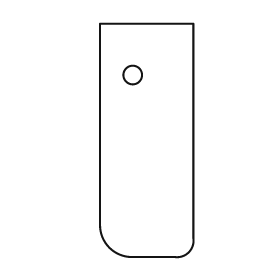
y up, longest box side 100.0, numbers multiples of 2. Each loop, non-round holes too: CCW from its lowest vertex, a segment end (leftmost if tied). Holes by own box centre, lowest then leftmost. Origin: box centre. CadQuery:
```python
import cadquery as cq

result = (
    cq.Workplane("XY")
    .moveTo(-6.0, -50.0)
    .lineTo(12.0, -50.0)
    .threePointArc((18.0, -48.0), (20.0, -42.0))
    .lineTo(20.0, 50.0)
    .lineTo(-20.0, 50.0)
    .lineTo(-20.0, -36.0)
    .threePointArc((-16.0, -46.0), (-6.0, -50.0))
    .close()
    .moveTo(-6.0, 28.0)
    .circle(4.0)
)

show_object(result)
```